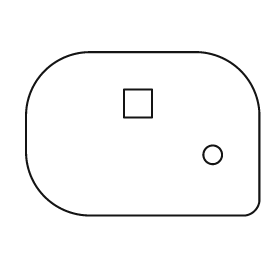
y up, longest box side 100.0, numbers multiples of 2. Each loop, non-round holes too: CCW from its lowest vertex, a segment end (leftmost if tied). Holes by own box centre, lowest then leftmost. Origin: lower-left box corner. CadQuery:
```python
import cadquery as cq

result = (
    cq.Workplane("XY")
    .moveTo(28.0, 0.0)
    .lineTo(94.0, 0.0)
    .threePointArc((98.0, 2.0), (100.0, 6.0))
    .lineTo(100.0, 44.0)
    .threePointArc((92.0, 62.0), (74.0, 70.0))
    .lineTo(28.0, 70.0)
    .threePointArc((8.0, 62.0), (0.0, 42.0))
    .lineTo(0.0, 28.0)
    .threePointArc((8.0, 8.0), (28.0, 0.0))
    .close()
    .moveTo(80.0, 26.0)
    .circle(4.0)
    .moveTo(42.0, 42.0)
    .lineTo(54.0, 42.0)
    .lineTo(54.0, 54.0)
    .lineTo(42.0, 54.0)
    .close()
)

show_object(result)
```